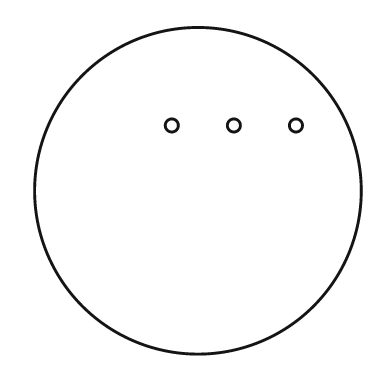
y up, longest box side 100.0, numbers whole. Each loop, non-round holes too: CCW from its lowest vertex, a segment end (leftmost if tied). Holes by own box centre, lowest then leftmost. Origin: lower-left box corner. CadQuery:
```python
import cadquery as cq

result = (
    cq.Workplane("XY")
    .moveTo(50.0, 50.0)
    .circle(50.0)
    .moveTo(42.0, 70.0)
    .circle(2.0)
    .moveTo(61.0, 70.0)
    .circle(2.0)
    .moveTo(80.0, 70.0)
    .circle(2.0)
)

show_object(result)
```